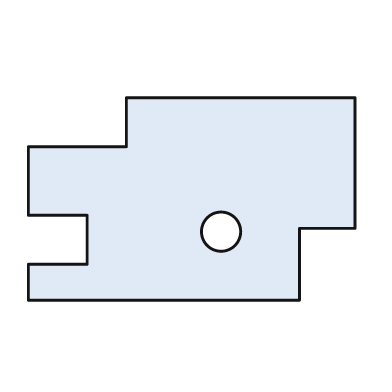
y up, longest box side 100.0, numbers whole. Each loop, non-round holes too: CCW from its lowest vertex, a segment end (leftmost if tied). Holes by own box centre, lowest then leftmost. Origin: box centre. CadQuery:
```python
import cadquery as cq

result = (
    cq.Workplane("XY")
    .moveTo(-50.0, -31.0)
    .lineTo(33.0, -31.0)
    .lineTo(33.0, -9.0)
    .lineTo(50.0, -9.0)
    .lineTo(50.0, 31.0)
    .lineTo(-20.0, 31.0)
    .lineTo(-20.0, 16.0)
    .lineTo(-50.0, 16.0)
    .lineTo(-50.0, -5.0)
    .lineTo(-32.0, -5.0)
    .lineTo(-32.0, -20.0)
    .lineTo(-50.0, -20.0)
    .close()
    .moveTo(9.0, -10.0)
    .circle(6.0)
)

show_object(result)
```